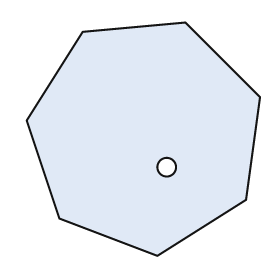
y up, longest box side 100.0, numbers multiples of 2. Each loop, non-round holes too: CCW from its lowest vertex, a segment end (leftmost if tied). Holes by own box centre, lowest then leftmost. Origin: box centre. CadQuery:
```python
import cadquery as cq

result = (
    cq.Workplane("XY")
    .moveTo(6.0, -50.0)
    .lineTo(44.0, -26.0)
    .lineTo(50.0, 18.0)
    .lineTo(18.0, 50.0)
    .lineTo(-26.0, 46.0)
    .lineTo(-50.0, 8.0)
    .lineTo(-36.0, -34.0)
    .close()
    .moveTo(10.0, -12.0)
    .circle(4.0)
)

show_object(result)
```